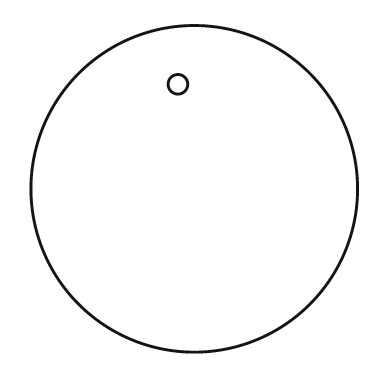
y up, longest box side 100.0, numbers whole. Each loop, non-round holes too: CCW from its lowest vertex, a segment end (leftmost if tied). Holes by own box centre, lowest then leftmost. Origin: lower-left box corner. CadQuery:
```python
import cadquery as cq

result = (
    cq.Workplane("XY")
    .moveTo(50.0, 50.0)
    .circle(50.0)
    .moveTo(45.0, 82.0)
    .circle(3.0)
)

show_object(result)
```